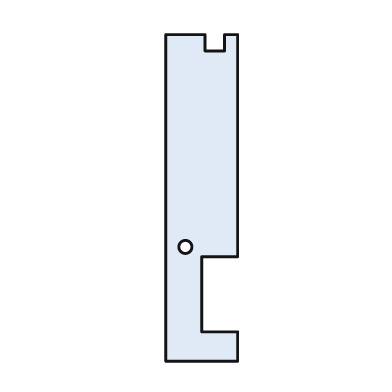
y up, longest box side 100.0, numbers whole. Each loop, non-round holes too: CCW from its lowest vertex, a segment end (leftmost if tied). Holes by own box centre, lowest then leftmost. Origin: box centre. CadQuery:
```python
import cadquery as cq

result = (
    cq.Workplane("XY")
    .moveTo(-11.0, -50.0)
    .lineTo(11.0, -50.0)
    .lineTo(11.0, -41.0)
    .lineTo(0.0, -41.0)
    .lineTo(0.0, -18.0)
    .lineTo(11.0, -18.0)
    .lineTo(11.0, 50.0)
    .lineTo(7.0, 50.0)
    .lineTo(7.0, 45.0)
    .lineTo(1.0, 45.0)
    .lineTo(1.0, 50.0)
    .lineTo(-11.0, 50.0)
    .close()
    .moveTo(-5.0, -15.0)
    .circle(2.0)
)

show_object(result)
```